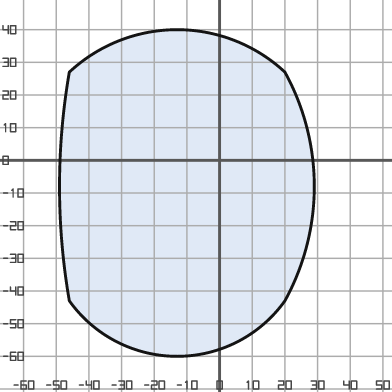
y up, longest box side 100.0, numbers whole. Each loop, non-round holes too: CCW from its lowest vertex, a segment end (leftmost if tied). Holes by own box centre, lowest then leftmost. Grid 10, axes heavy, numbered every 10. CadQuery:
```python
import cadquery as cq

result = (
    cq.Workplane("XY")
    .moveTo(-46.0, -43.0)
    .threePointArc((-13.0, -60.0), (20.0, -43.0))
    .threePointArc((29.0, -8.0), (20.0, 27.0))
    .threePointArc((-13.0, 40.0), (-46.0, 27.0))
    .threePointArc((-49.0, -8.0), (-46.0, -43.0))
    .close()
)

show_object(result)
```